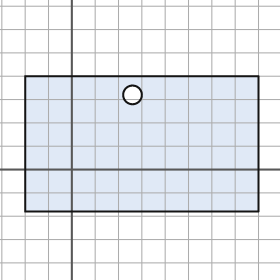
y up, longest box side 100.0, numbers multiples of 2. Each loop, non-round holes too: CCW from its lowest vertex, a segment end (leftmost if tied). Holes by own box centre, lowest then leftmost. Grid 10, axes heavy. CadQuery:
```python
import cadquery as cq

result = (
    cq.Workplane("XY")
    .moveTo(-20.0, -18.0)
    .lineTo(80.0, -18.0)
    .lineTo(80.0, 40.0)
    .lineTo(-20.0, 40.0)
    .close()
    .moveTo(26.0, 32.0)
    .circle(4.0)
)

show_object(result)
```